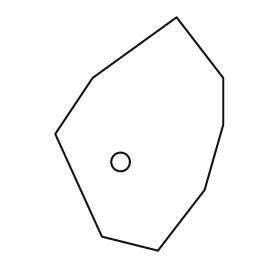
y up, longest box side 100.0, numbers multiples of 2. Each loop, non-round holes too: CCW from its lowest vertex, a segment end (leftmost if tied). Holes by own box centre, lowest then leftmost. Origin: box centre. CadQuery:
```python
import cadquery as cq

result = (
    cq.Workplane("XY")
    .moveTo(8.0, -50.0)
    .lineTo(28.0, -24.0)
    .lineTo(36.0, 4.0)
    .lineTo(36.0, 24.0)
    .lineTo(16.0, 50.0)
    .lineTo(-20.0, 24.0)
    .lineTo(-36.0, 0.0)
    .lineTo(-16.0, -44.0)
    .close()
    .moveTo(-8.0, -12.0)
    .circle(4.0)
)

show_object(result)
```